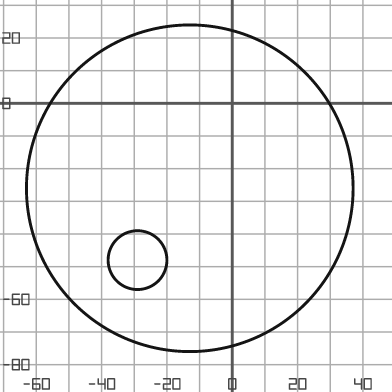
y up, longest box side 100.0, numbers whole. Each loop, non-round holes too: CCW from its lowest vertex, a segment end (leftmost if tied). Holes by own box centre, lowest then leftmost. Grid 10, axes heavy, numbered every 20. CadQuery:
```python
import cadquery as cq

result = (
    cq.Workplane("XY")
    .moveTo(-13.0, -26.0)
    .circle(50.0)
    .moveTo(-29.0, -48.0)
    .circle(9.0)
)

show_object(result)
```